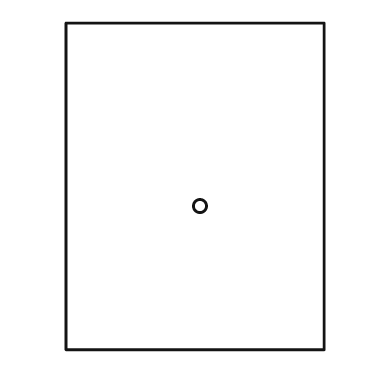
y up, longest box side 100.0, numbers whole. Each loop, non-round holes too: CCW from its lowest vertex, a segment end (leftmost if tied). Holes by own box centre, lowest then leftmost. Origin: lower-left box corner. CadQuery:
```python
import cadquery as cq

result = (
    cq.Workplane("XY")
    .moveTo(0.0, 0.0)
    .lineTo(79.0, 0.0)
    .lineTo(79.0, 100.0)
    .lineTo(0.0, 100.0)
    .close()
    .moveTo(41.0, 44.0)
    .circle(2.0)
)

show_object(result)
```